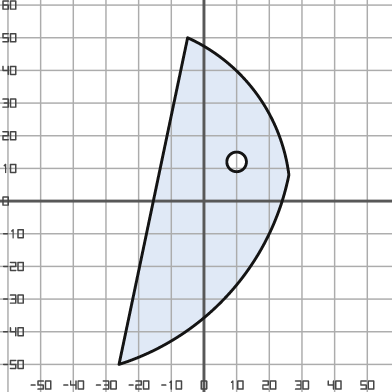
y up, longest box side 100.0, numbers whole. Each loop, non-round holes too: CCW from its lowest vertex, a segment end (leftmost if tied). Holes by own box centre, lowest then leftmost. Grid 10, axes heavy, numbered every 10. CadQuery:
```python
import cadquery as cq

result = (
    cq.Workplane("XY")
    .moveTo(-26.0, -50.0)
    .threePointArc((8.0, -28.0), (26.0, 8.0))
    .threePointArc((16.0, 33.0), (-5.0, 50.0))
    .close()
    .moveTo(10.0, 12.0)
    .circle(3.0)
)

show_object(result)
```